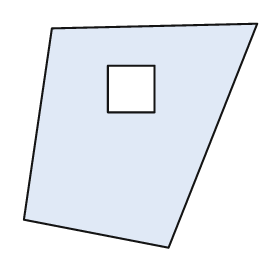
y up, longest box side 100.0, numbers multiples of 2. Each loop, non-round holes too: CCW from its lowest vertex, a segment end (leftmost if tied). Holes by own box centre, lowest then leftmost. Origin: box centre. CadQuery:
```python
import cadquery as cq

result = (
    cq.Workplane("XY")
    .moveTo(12.0, -48.0)
    .lineTo(50.0, 48.0)
    .lineTo(-38.0, 46.0)
    .lineTo(-50.0, -36.0)
    .close()
    .moveTo(-14.0, 10.0)
    .lineTo(6.0, 10.0)
    .lineTo(6.0, 30.0)
    .lineTo(-14.0, 30.0)
    .close()
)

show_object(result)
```